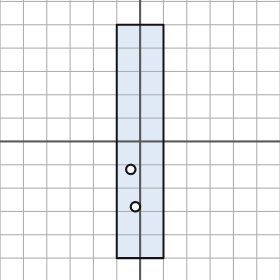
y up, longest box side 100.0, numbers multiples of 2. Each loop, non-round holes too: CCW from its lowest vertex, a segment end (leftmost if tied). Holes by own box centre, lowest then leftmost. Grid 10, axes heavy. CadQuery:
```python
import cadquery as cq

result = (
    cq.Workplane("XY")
    .moveTo(-10.0, -50.0)
    .lineTo(10.0, -50.0)
    .lineTo(10.0, 50.0)
    .lineTo(-10.0, 50.0)
    .close()
    .moveTo(-2.0, -28.0)
    .circle(2.0)
    .moveTo(-4.0, -12.0)
    .circle(2.0)
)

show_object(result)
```